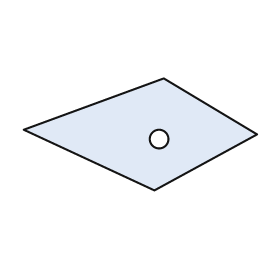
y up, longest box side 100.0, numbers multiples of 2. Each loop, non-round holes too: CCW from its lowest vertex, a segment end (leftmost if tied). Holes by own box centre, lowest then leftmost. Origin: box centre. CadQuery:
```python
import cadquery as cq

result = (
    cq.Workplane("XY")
    .moveTo(6.0, -24.0)
    .lineTo(50.0, 0.0)
    .lineTo(10.0, 24.0)
    .lineTo(-50.0, 2.0)
    .close()
    .moveTo(8.0, -2.0)
    .circle(4.0)
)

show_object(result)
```